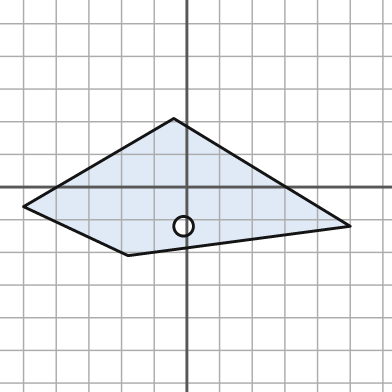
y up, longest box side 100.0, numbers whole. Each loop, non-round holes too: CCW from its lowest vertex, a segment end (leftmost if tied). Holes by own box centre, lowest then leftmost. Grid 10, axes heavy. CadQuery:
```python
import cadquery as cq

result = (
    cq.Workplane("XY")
    .moveTo(-18.0, -21.0)
    .lineTo(50.0, -12.0)
    .lineTo(-4.0, 21.0)
    .lineTo(-50.0, -6.0)
    .close()
    .moveTo(-1.0, -12.0)
    .circle(3.0)
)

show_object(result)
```